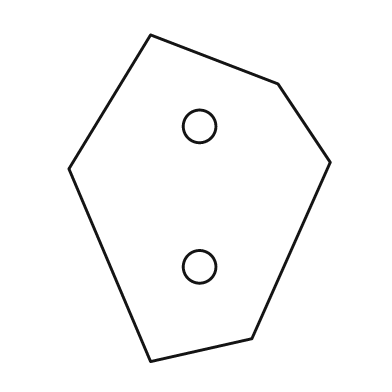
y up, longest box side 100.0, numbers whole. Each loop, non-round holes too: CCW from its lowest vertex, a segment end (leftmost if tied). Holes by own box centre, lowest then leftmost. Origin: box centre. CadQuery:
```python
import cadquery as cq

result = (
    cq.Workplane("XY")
    .moveTo(-15.0, -50.0)
    .lineTo(16.0, -43.0)
    .lineTo(40.0, 11.0)
    .lineTo(24.0, 35.0)
    .lineTo(-15.0, 50.0)
    .lineTo(-40.0, 9.0)
    .close()
    .moveTo(0.0, -21.0)
    .circle(5.0)
    .moveTo(0.0, 22.0)
    .circle(5.0)
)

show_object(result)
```